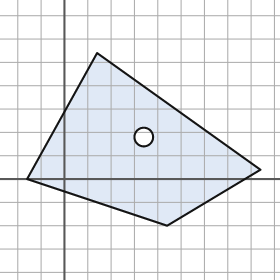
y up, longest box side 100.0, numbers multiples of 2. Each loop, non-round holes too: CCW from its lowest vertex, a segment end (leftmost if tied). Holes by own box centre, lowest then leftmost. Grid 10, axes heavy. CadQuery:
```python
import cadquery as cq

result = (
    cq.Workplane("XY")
    .moveTo(44.0, -20.0)
    .lineTo(84.0, 4.0)
    .lineTo(14.0, 54.0)
    .lineTo(-16.0, 0.0)
    .close()
    .moveTo(34.0, 18.0)
    .circle(4.0)
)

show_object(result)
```